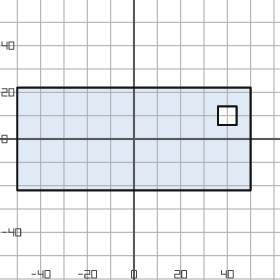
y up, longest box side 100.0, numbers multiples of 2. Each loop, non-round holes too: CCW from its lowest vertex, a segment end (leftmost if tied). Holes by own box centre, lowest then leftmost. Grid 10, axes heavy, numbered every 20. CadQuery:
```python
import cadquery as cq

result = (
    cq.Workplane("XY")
    .moveTo(-50.0, -22.0)
    .lineTo(50.0, -22.0)
    .lineTo(50.0, 22.0)
    .lineTo(-50.0, 22.0)
    .close()
    .moveTo(36.0, 6.0)
    .lineTo(44.0, 6.0)
    .lineTo(44.0, 14.0)
    .lineTo(36.0, 14.0)
    .close()
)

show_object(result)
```